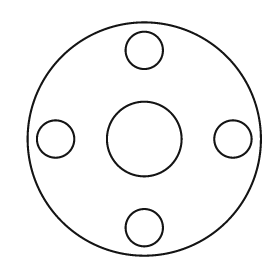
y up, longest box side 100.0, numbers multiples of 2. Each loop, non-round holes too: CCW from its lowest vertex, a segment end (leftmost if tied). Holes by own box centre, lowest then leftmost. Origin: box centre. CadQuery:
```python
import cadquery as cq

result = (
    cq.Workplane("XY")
    .moveTo(0.0, 0.0)
    .circle(50.0)
    .moveTo(0.0, -38.0)
    .circle(8.0)
    .moveTo(-38.0, 0.0)
    .circle(8.0)
    .moveTo(0.0, 0.0)
    .circle(16.0)
    .moveTo(38.0, 0.0)
    .circle(8.0)
    .moveTo(0.0, 38.0)
    .circle(8.0)
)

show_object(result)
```